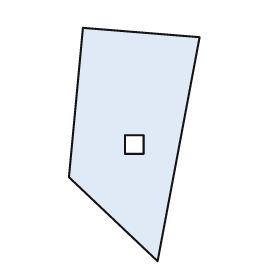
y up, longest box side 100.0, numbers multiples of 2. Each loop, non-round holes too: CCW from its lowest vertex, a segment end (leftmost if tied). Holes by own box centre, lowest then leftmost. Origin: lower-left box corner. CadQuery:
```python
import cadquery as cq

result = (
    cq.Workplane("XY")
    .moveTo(38.0, 0.0)
    .lineTo(56.0, 96.0)
    .lineTo(6.0, 100.0)
    .lineTo(0.0, 36.0)
    .close()
    .moveTo(24.0, 46.0)
    .lineTo(32.0, 46.0)
    .lineTo(32.0, 54.0)
    .lineTo(24.0, 54.0)
    .close()
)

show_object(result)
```